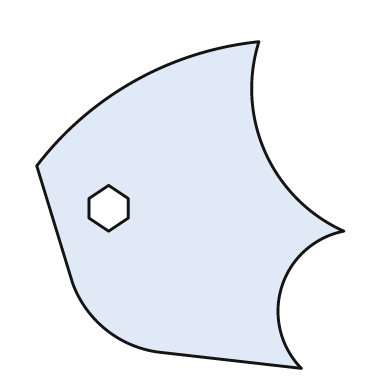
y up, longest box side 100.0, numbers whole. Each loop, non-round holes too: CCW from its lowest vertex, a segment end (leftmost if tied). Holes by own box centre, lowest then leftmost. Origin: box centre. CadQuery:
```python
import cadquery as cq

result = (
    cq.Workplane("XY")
    .moveTo(34.0, -50.0)
    .threePointArc((28.0, -25.0), (47.0, -8.0))
    .threePointArc((23.0, 16.0), (21.0, 50.0))
    .threePointArc((-17.0, 38.0), (-47.0, 12.0))
    .lineTo(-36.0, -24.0)
    .threePointArc((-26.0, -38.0), (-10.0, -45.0))
    .close()
    .moveTo(-25.0, -8.0)
    .lineTo(-19.0, -4.0)
    .lineTo(-19.0, 2.0)
    .lineTo(-25.0, 6.0)
    .lineTo(-31.0, 2.0)
    .lineTo(-31.0, -4.0)
    .close()
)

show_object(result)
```